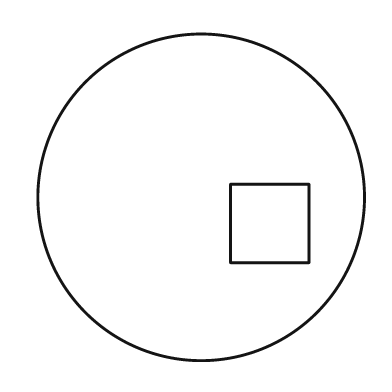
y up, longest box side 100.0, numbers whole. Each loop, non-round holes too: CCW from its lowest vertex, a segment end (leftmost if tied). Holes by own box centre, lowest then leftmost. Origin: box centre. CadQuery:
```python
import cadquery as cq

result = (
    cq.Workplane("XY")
    .moveTo(0.0, 0.0)
    .circle(50.0)
    .moveTo(9.0, -20.0)
    .lineTo(33.0, -20.0)
    .lineTo(33.0, 4.0)
    .lineTo(9.0, 4.0)
    .close()
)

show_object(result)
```